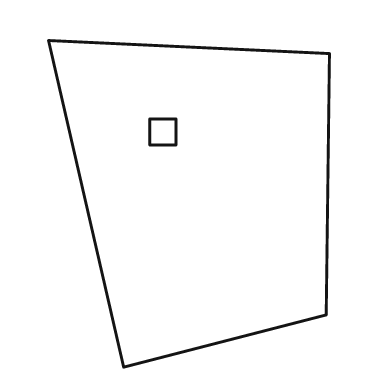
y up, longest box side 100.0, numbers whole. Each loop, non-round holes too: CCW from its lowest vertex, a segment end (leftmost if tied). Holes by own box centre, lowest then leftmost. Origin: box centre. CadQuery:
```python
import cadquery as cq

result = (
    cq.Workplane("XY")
    .moveTo(-20.0, -50.0)
    .lineTo(42.0, -34.0)
    .lineTo(43.0, 46.0)
    .lineTo(-43.0, 50.0)
    .close()
    .moveTo(-12.0, 18.0)
    .lineTo(-4.0, 18.0)
    .lineTo(-4.0, 26.0)
    .lineTo(-12.0, 26.0)
    .close()
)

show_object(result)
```